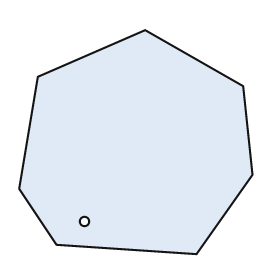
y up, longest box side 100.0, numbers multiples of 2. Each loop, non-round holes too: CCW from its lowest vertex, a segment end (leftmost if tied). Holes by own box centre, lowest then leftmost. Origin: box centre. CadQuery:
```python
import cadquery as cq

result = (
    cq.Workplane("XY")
    .moveTo(26.0, -48.0)
    .lineTo(50.0, -14.0)
    .lineTo(46.0, 24.0)
    .lineTo(4.0, 48.0)
    .lineTo(-42.0, 28.0)
    .lineTo(-50.0, -20.0)
    .lineTo(-34.0, -44.0)
    .close()
    .moveTo(-22.0, -34.0)
    .circle(2.0)
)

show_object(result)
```